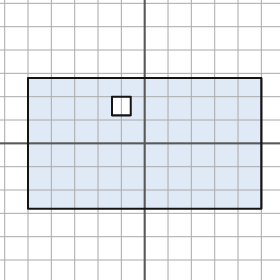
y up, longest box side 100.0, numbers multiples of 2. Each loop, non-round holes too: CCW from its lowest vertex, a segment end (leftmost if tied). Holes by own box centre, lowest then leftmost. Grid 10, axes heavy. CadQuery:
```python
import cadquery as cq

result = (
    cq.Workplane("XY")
    .moveTo(-50.0, -28.0)
    .lineTo(50.0, -28.0)
    .lineTo(50.0, 28.0)
    .lineTo(-50.0, 28.0)
    .close()
    .moveTo(-14.0, 12.0)
    .lineTo(-6.0, 12.0)
    .lineTo(-6.0, 20.0)
    .lineTo(-14.0, 20.0)
    .close()
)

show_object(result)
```